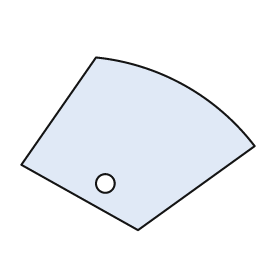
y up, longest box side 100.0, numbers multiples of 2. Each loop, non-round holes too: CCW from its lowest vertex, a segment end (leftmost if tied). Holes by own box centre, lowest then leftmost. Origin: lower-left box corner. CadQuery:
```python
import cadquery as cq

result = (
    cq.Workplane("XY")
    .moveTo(50.0, 0.0)
    .lineTo(100.0, 36.0)
    .threePointArc((70.0, 62.0), (32.0, 74.0))
    .lineTo(0.0, 28.0)
    .close()
    .moveTo(36.0, 20.0)
    .circle(4.0)
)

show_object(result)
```